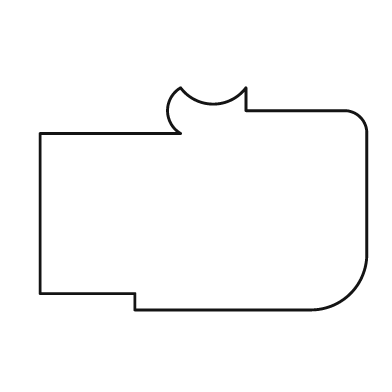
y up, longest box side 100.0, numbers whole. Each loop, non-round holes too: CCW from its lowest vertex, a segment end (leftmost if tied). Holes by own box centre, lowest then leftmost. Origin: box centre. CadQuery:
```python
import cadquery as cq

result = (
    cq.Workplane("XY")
    .moveTo(-21.0, -34.0)
    .lineTo(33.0, -34.0)
    .threePointArc((45.0, -29.0), (50.0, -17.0))
    .lineTo(50.0, 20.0)
    .threePointArc((48.0, 25.0), (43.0, 27.0))
    .lineTo(13.0, 27.0)
    .lineTo(13.0, 34.0)
    .threePointArc((3.0, 29.0), (-7.0, 34.0))
    .threePointArc((-11.0, 27.0), (-7.0, 20.0))
    .lineTo(-50.0, 20.0)
    .lineTo(-50.0, -29.0)
    .lineTo(-21.0, -29.0)
    .close()
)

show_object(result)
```